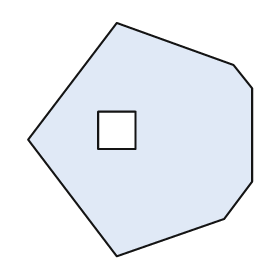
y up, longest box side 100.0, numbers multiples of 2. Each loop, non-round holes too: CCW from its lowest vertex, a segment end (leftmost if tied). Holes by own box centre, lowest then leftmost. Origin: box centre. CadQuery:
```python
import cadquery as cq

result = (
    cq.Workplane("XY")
    .moveTo(-10.0, -50.0)
    .lineTo(36.0, -34.0)
    .lineTo(48.0, -18.0)
    .lineTo(48.0, 22.0)
    .lineTo(40.0, 32.0)
    .lineTo(-10.0, 50.0)
    .lineTo(-48.0, 0.0)
    .close()
    .moveTo(-18.0, -4.0)
    .lineTo(-2.0, -4.0)
    .lineTo(-2.0, 12.0)
    .lineTo(-18.0, 12.0)
    .close()
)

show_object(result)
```